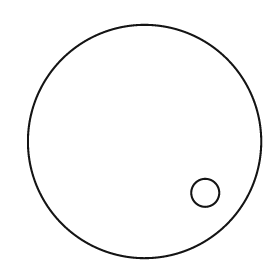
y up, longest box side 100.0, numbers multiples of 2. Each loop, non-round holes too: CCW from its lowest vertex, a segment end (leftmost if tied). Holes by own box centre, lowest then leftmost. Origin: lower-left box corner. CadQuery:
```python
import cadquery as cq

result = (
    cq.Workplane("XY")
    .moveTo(50.0, 50.0)
    .circle(50.0)
    .moveTo(76.0, 28.0)
    .circle(6.0)
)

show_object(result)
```